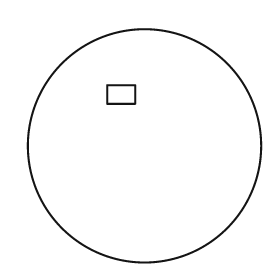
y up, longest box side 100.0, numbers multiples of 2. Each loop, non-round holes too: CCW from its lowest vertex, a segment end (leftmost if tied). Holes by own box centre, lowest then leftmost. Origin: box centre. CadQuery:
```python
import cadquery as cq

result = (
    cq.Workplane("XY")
    .moveTo(0.0, 0.0)
    .circle(50.0)
    .moveTo(-16.0, 18.0)
    .lineTo(-4.0, 18.0)
    .lineTo(-4.0, 26.0)
    .lineTo(-16.0, 26.0)
    .close()
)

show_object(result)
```